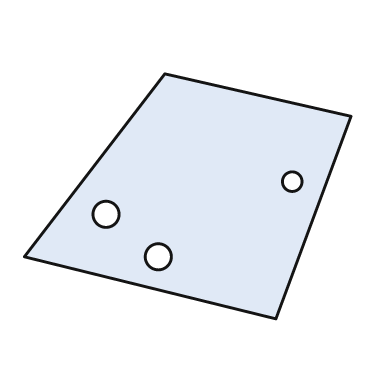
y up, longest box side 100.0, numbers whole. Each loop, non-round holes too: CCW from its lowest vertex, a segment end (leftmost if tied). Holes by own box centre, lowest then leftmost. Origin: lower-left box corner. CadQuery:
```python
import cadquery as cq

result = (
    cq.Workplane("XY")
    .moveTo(77.0, 0.0)
    .lineTo(100.0, 62.0)
    .lineTo(43.0, 75.0)
    .lineTo(0.0, 19.0)
    .close()
    .moveTo(41.0, 19.0)
    .circle(4.0)
    .moveTo(25.0, 32.0)
    .circle(4.0)
    .moveTo(82.0, 42.0)
    .circle(3.0)
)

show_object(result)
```